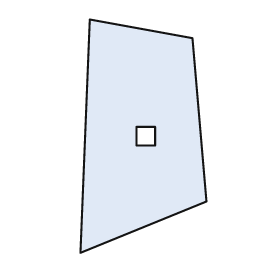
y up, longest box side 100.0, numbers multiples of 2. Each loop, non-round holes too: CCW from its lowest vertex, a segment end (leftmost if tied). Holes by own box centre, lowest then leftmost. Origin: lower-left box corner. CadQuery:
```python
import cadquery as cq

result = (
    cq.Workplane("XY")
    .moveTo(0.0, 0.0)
    .lineTo(54.0, 22.0)
    .lineTo(48.0, 92.0)
    .lineTo(4.0, 100.0)
    .close()
    .moveTo(24.0, 46.0)
    .lineTo(32.0, 46.0)
    .lineTo(32.0, 54.0)
    .lineTo(24.0, 54.0)
    .close()
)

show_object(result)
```